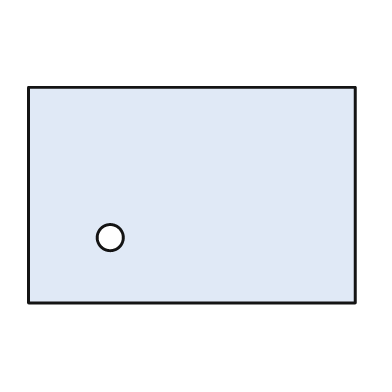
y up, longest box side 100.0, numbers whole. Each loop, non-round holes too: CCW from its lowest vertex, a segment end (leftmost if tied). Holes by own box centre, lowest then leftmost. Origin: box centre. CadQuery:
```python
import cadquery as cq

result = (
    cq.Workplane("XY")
    .moveTo(-50.0, -33.0)
    .lineTo(50.0, -33.0)
    .lineTo(50.0, 33.0)
    .lineTo(-50.0, 33.0)
    .close()
    .moveTo(-25.0, -13.0)
    .circle(4.0)
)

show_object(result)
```